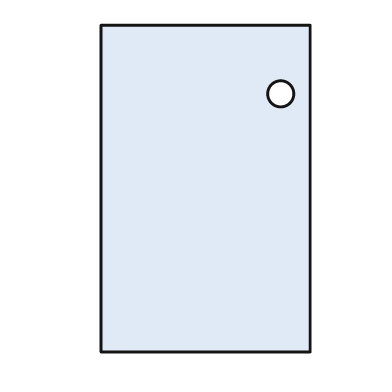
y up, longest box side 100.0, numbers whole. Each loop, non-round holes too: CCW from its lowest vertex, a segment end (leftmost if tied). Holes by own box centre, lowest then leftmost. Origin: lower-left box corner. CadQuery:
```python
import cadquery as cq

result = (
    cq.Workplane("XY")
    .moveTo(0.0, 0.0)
    .lineTo(64.0, 0.0)
    .lineTo(64.0, 100.0)
    .lineTo(0.0, 100.0)
    .close()
    .moveTo(55.0, 79.0)
    .circle(4.0)
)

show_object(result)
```